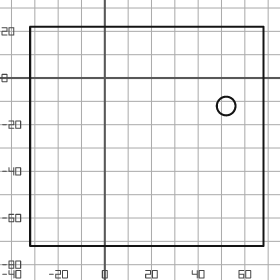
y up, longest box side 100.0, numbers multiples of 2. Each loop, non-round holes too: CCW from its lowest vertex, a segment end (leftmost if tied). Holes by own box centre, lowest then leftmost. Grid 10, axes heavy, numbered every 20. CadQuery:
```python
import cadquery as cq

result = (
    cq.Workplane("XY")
    .moveTo(-32.0, -72.0)
    .lineTo(68.0, -72.0)
    .lineTo(68.0, 22.0)
    .lineTo(-32.0, 22.0)
    .close()
    .moveTo(52.0, -12.0)
    .circle(4.0)
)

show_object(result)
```